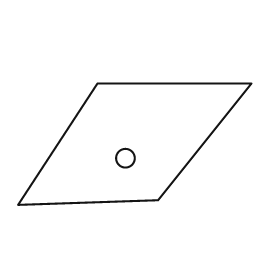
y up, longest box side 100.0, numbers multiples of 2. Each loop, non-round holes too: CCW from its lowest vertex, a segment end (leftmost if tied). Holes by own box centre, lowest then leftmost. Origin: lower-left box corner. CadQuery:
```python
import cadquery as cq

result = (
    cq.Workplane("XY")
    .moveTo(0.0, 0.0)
    .lineTo(60.0, 2.0)
    .lineTo(100.0, 52.0)
    .lineTo(34.0, 52.0)
    .close()
    .moveTo(46.0, 20.0)
    .circle(4.0)
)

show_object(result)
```